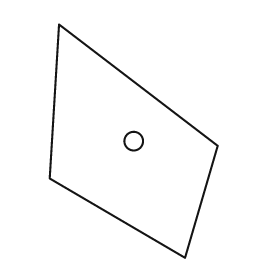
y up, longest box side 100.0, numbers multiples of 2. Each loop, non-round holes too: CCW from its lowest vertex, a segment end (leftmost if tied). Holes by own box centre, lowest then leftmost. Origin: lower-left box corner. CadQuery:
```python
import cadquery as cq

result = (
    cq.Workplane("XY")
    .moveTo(58.0, 0.0)
    .lineTo(72.0, 48.0)
    .lineTo(4.0, 100.0)
    .lineTo(0.0, 34.0)
    .close()
    .moveTo(36.0, 50.0)
    .circle(4.0)
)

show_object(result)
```